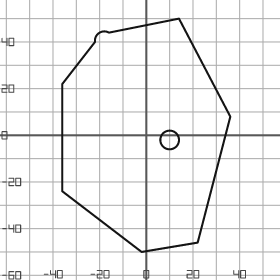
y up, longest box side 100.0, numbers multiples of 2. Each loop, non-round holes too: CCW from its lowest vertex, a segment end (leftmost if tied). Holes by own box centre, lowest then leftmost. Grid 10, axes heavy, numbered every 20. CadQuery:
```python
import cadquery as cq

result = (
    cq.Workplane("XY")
    .moveTo(-2.0, -50.0)
    .lineTo(22.0, -46.0)
    .lineTo(36.0, 8.0)
    .lineTo(14.0, 50.0)
    .lineTo(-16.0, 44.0)
    .threePointArc((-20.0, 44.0), (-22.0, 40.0))
    .lineTo(-36.0, 22.0)
    .lineTo(-36.0, -24.0)
    .close()
    .moveTo(10.0, -2.0)
    .circle(4.0)
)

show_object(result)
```